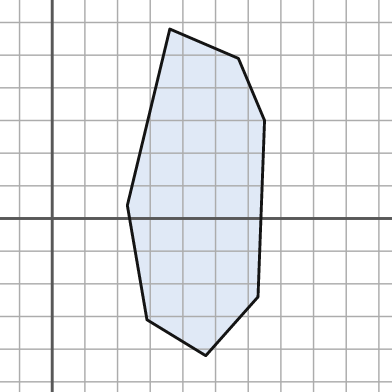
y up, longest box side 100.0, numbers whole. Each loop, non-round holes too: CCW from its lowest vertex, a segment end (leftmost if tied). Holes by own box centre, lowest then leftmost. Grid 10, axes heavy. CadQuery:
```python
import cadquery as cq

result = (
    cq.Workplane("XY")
    .moveTo(47.0, -42.0)
    .lineTo(63.0, -24.0)
    .lineTo(65.0, 30.0)
    .lineTo(57.0, 49.0)
    .lineTo(36.0, 58.0)
    .lineTo(23.0, 4.0)
    .lineTo(29.0, -31.0)
    .close()
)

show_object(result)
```